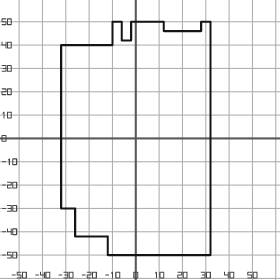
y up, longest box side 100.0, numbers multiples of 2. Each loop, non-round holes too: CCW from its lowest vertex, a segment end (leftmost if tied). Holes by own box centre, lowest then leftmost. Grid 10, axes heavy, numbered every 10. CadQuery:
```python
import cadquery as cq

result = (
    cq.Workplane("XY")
    .moveTo(-12.0, -50.0)
    .lineTo(32.0, -50.0)
    .lineTo(32.0, 50.0)
    .lineTo(28.0, 50.0)
    .lineTo(28.0, 46.0)
    .lineTo(12.0, 46.0)
    .lineTo(12.0, 50.0)
    .lineTo(-2.0, 50.0)
    .lineTo(-2.0, 42.0)
    .lineTo(-6.0, 42.0)
    .lineTo(-6.0, 50.0)
    .lineTo(-10.0, 50.0)
    .lineTo(-10.0, 40.0)
    .lineTo(-32.0, 40.0)
    .lineTo(-32.0, -30.0)
    .lineTo(-26.0, -30.0)
    .lineTo(-26.0, -42.0)
    .lineTo(-12.0, -42.0)
    .close()
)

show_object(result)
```